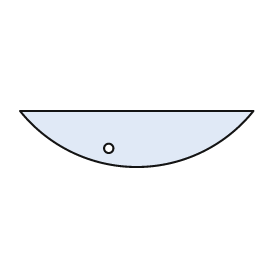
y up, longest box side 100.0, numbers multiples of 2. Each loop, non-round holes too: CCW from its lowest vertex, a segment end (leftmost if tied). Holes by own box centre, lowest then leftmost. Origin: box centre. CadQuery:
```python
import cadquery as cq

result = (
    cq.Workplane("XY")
    .moveTo(-50.0, 12.0)
    .threePointArc((0.0, -12.0), (50.0, 12.0))
    .close()
    .moveTo(-12.0, -4.0)
    .circle(2.0)
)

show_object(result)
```